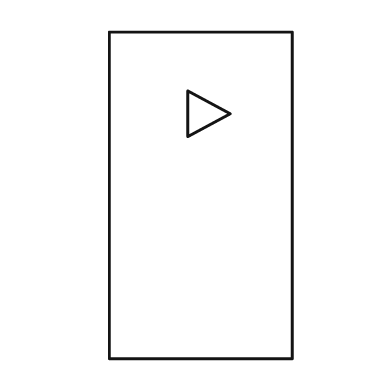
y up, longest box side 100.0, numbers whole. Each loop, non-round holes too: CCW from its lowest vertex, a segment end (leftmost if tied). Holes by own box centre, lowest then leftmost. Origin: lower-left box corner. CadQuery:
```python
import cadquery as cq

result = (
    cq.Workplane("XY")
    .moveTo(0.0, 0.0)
    .lineTo(56.0, 0.0)
    .lineTo(56.0, 100.0)
    .lineTo(0.0, 100.0)
    .close()
    .moveTo(24.0, 68.0)
    .lineTo(37.0, 75.0)
    .lineTo(24.0, 82.0)
    .close()
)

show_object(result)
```